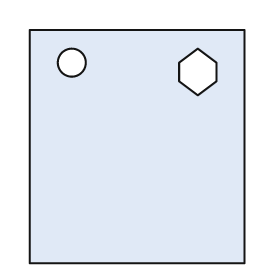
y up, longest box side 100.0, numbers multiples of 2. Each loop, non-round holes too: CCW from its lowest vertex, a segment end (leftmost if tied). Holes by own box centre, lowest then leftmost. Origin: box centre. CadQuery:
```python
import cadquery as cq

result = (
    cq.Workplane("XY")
    .moveTo(-46.0, -50.0)
    .lineTo(46.0, -50.0)
    .lineTo(46.0, 50.0)
    .lineTo(-46.0, 50.0)
    .close()
    .moveTo(26.0, 22.0)
    .lineTo(34.0, 28.0)
    .lineTo(34.0, 36.0)
    .lineTo(26.0, 42.0)
    .lineTo(18.0, 36.0)
    .lineTo(18.0, 28.0)
    .close()
    .moveTo(-28.0, 36.0)
    .circle(6.0)
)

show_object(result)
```